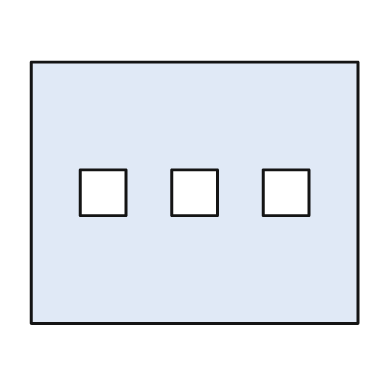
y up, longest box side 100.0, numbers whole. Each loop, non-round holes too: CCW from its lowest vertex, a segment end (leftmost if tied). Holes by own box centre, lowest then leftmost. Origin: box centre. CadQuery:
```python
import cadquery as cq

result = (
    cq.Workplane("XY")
    .moveTo(-50.0, -40.0)
    .lineTo(50.0, -40.0)
    .lineTo(50.0, 40.0)
    .lineTo(-50.0, 40.0)
    .close()
    .moveTo(-35.0, -7.0)
    .lineTo(-21.0, -7.0)
    .lineTo(-21.0, 7.0)
    .lineTo(-35.0, 7.0)
    .close()
    .moveTo(-7.0, -7.0)
    .lineTo(7.0, -7.0)
    .lineTo(7.0, 7.0)
    .lineTo(-7.0, 7.0)
    .close()
    .moveTo(21.0, -7.0)
    .lineTo(35.0, -7.0)
    .lineTo(35.0, 7.0)
    .lineTo(21.0, 7.0)
    .close()
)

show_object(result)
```